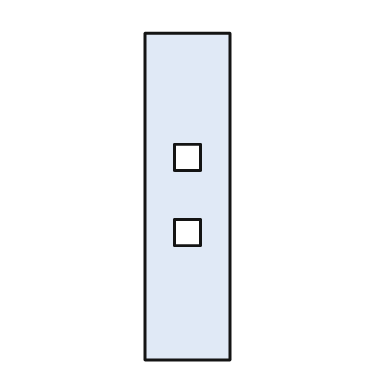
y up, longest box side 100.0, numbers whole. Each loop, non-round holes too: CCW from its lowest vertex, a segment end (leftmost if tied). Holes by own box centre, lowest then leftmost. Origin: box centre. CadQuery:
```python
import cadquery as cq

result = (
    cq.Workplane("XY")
    .moveTo(-13.0, -50.0)
    .lineTo(13.0, -50.0)
    .lineTo(13.0, 50.0)
    .lineTo(-13.0, 50.0)
    .close()
    .moveTo(-4.0, -15.0)
    .lineTo(4.0, -15.0)
    .lineTo(4.0, -7.0)
    .lineTo(-4.0, -7.0)
    .close()
    .moveTo(-4.0, 8.0)
    .lineTo(4.0, 8.0)
    .lineTo(4.0, 16.0)
    .lineTo(-4.0, 16.0)
    .close()
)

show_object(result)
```